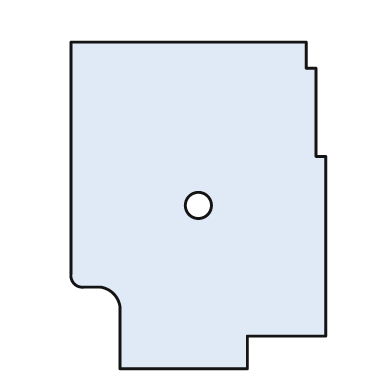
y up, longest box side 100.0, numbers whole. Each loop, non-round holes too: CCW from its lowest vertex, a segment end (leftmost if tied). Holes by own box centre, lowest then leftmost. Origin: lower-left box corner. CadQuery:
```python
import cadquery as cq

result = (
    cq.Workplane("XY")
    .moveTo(15.0, 0.0)
    .lineTo(54.0, 0.0)
    .lineTo(54.0, 10.0)
    .lineTo(78.0, 10.0)
    .lineTo(78.0, 65.0)
    .lineTo(75.0, 65.0)
    .lineTo(75.0, 92.0)
    .lineTo(72.0, 92.0)
    .lineTo(72.0, 100.0)
    .lineTo(0.0, 100.0)
    .lineTo(0.0, 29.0)
    .threePointArc((1.0, 26.0), (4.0, 25.0))
    .lineTo(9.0, 25.0)
    .threePointArc((13.0, 23.0), (15.0, 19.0))
    .close()
    .moveTo(39.0, 50.0)
    .circle(4.0)
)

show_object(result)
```